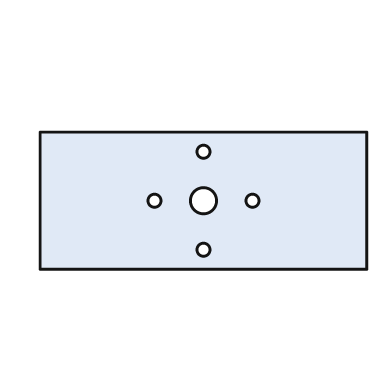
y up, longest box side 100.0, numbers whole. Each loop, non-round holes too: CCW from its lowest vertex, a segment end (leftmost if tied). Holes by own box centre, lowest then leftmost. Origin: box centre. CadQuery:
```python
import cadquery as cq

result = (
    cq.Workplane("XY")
    .moveTo(-50.0, -21.0)
    .lineTo(50.0, -21.0)
    .lineTo(50.0, 21.0)
    .lineTo(-50.0, 21.0)
    .close()
    .moveTo(0.0, -15.0)
    .circle(2.0)
    .moveTo(-15.0, 0.0)
    .circle(2.0)
    .moveTo(0.0, 0.0)
    .circle(4.0)
    .moveTo(15.0, 0.0)
    .circle(2.0)
    .moveTo(0.0, 15.0)
    .circle(2.0)
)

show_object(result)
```